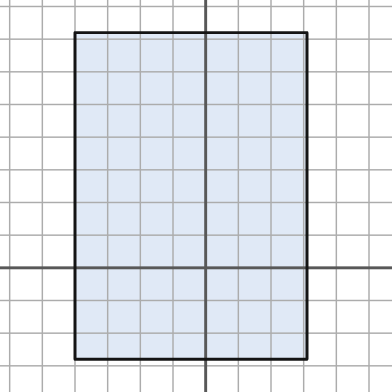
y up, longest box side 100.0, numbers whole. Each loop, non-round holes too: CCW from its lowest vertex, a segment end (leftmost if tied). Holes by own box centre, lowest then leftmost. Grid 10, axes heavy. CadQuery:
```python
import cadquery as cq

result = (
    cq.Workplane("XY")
    .moveTo(-40.0, -28.0)
    .lineTo(31.0, -28.0)
    .lineTo(31.0, 72.0)
    .lineTo(-40.0, 72.0)
    .close()
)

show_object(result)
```